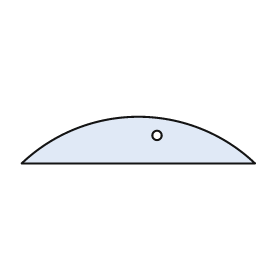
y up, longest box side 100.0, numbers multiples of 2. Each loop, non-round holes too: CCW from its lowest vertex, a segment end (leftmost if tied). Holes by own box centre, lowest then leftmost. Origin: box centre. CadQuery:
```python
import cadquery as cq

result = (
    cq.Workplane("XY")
    .moveTo(-50.0, -10.0)
    .lineTo(50.0, -10.0)
    .threePointArc((0.0, 10.0), (-50.0, -10.0))
    .close()
    .moveTo(8.0, 2.0)
    .circle(2.0)
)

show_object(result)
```